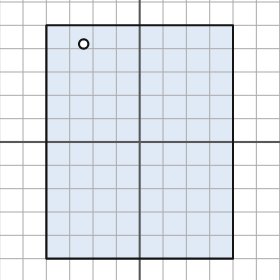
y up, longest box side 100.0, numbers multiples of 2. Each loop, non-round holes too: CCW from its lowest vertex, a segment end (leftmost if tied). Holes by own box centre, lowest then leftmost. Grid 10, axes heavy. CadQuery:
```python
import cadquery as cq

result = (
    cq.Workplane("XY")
    .moveTo(-40.0, -50.0)
    .lineTo(40.0, -50.0)
    .lineTo(40.0, 50.0)
    .lineTo(-40.0, 50.0)
    .close()
    .moveTo(-24.0, 42.0)
    .circle(2.0)
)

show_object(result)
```